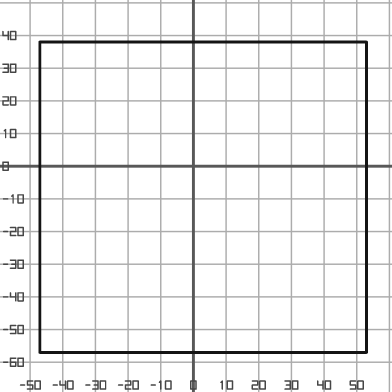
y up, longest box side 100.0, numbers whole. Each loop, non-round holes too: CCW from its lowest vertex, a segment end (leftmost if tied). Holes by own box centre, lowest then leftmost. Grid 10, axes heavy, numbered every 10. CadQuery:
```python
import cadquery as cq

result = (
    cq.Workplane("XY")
    .moveTo(-47.0, -57.0)
    .lineTo(53.0, -57.0)
    .lineTo(53.0, 38.0)
    .lineTo(-47.0, 38.0)
    .close()
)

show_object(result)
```